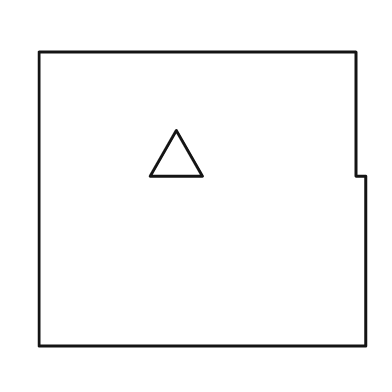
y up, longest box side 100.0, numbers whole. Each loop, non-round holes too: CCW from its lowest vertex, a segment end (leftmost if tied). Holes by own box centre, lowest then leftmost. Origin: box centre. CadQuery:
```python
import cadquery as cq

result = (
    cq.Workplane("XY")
    .moveTo(-50.0, -45.0)
    .lineTo(50.0, -45.0)
    .lineTo(50.0, 7.0)
    .lineTo(47.0, 7.0)
    .lineTo(47.0, 45.0)
    .lineTo(-50.0, 45.0)
    .close()
    .moveTo(-16.0, 7.0)
    .lineTo(0.0, 7.0)
    .lineTo(-8.0, 21.0)
    .close()
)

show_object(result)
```